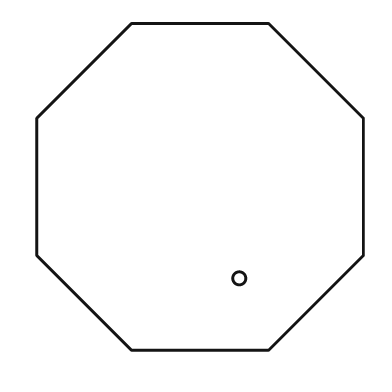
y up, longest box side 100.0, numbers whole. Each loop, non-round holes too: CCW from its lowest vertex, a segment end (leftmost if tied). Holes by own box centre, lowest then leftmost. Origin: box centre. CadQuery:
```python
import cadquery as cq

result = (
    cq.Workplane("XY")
    .moveTo(-21.0, -50.0)
    .lineTo(21.0, -50.0)
    .lineTo(50.0, -21.0)
    .lineTo(50.0, 21.0)
    .lineTo(21.0, 50.0)
    .lineTo(-21.0, 50.0)
    .lineTo(-50.0, 21.0)
    .lineTo(-50.0, -21.0)
    .close()
    .moveTo(12.0, -28.0)
    .circle(2.0)
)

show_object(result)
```